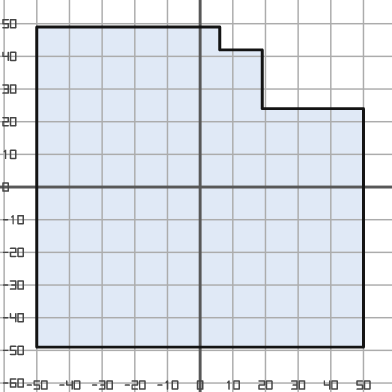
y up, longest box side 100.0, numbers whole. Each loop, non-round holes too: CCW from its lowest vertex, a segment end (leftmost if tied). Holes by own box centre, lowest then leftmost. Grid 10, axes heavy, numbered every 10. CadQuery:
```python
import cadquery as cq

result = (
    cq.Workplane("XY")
    .moveTo(-50.0, -49.0)
    .lineTo(50.0, -49.0)
    .lineTo(50.0, 24.0)
    .lineTo(19.0, 24.0)
    .lineTo(19.0, 42.0)
    .lineTo(6.0, 42.0)
    .lineTo(6.0, 49.0)
    .lineTo(-50.0, 49.0)
    .close()
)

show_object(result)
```